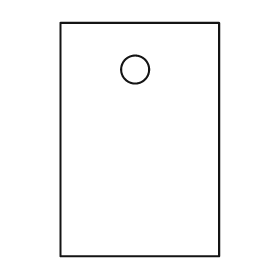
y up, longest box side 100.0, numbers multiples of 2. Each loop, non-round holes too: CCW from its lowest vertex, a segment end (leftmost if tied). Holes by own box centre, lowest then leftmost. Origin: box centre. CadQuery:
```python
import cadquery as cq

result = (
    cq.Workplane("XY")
    .moveTo(-34.0, -50.0)
    .lineTo(34.0, -50.0)
    .lineTo(34.0, 50.0)
    .lineTo(-34.0, 50.0)
    .close()
    .moveTo(-2.0, 30.0)
    .circle(6.0)
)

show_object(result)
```